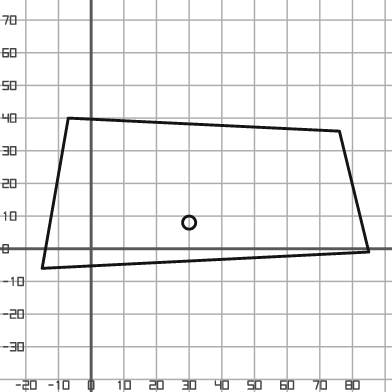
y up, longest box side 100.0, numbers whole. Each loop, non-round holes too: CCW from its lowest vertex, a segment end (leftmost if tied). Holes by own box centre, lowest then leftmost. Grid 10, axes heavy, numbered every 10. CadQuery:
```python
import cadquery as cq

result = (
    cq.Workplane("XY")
    .moveTo(-15.0, -6.0)
    .lineTo(85.0, -1.0)
    .lineTo(76.0, 36.0)
    .lineTo(-7.0, 40.0)
    .close()
    .moveTo(30.0, 8.0)
    .circle(2.0)
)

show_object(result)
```